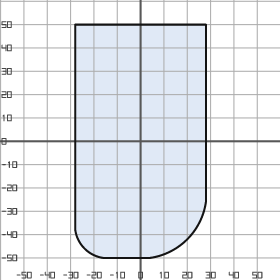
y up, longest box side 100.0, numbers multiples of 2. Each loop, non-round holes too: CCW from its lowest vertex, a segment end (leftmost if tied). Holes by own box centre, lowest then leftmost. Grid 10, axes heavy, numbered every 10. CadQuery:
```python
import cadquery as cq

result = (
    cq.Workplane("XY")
    .moveTo(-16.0, -50.0)
    .lineTo(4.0, -50.0)
    .threePointArc((20.0, -42.0), (28.0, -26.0))
    .lineTo(28.0, 50.0)
    .lineTo(-28.0, 50.0)
    .lineTo(-28.0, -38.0)
    .threePointArc((-24.0, -46.0), (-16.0, -50.0))
    .close()
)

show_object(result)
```